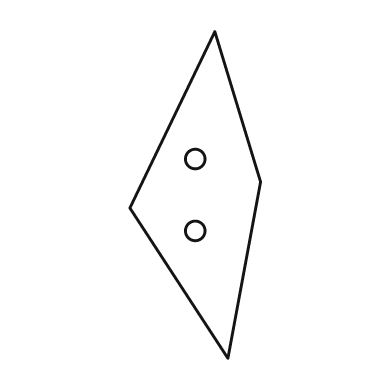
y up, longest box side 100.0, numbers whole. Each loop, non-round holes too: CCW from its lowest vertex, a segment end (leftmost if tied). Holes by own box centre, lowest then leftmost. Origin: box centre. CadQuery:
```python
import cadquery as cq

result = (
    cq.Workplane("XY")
    .moveTo(10.0, -50.0)
    .lineTo(20.0, 4.0)
    .lineTo(6.0, 50.0)
    .lineTo(-20.0, -4.0)
    .close()
    .moveTo(0.0, -11.0)
    .circle(3.0)
    .moveTo(0.0, 11.0)
    .circle(3.0)
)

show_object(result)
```